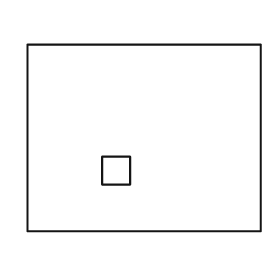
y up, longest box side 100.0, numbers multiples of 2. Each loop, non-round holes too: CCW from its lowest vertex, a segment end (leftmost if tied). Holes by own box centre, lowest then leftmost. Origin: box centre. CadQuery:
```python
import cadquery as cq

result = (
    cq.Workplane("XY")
    .moveTo(-50.0, -40.0)
    .lineTo(50.0, -40.0)
    .lineTo(50.0, 40.0)
    .lineTo(-50.0, 40.0)
    .close()
    .moveTo(-18.0, -20.0)
    .lineTo(-6.0, -20.0)
    .lineTo(-6.0, -8.0)
    .lineTo(-18.0, -8.0)
    .close()
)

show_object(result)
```